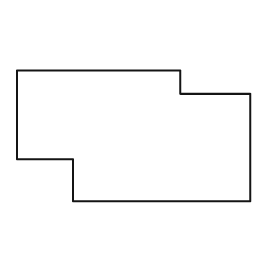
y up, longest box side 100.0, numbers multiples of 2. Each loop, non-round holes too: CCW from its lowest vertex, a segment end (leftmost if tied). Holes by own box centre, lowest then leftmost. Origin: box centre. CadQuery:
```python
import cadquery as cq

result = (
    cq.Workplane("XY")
    .moveTo(-26.0, -28.0)
    .lineTo(50.0, -28.0)
    .lineTo(50.0, 18.0)
    .lineTo(20.0, 18.0)
    .lineTo(20.0, 28.0)
    .lineTo(-50.0, 28.0)
    .lineTo(-50.0, -10.0)
    .lineTo(-26.0, -10.0)
    .close()
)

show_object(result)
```